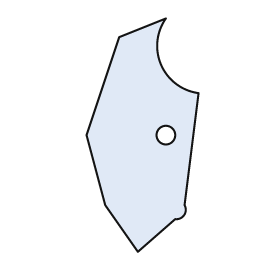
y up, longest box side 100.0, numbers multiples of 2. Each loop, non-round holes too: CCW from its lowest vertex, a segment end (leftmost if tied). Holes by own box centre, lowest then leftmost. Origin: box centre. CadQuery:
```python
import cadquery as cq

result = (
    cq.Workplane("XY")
    .moveTo(-2.0, -50.0)
    .lineTo(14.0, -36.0)
    .threePointArc((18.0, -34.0), (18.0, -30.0))
    .lineTo(24.0, 18.0)
    .threePointArc((8.0, 30.0), (10.0, 50.0))
    .lineTo(-10.0, 42.0)
    .lineTo(-24.0, 0.0)
    .lineTo(-16.0, -30.0)
    .close()
    .moveTo(10.0, 0.0)
    .circle(4.0)
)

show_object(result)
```